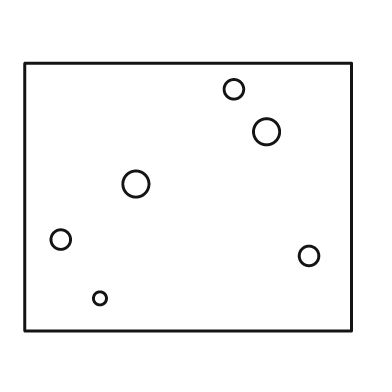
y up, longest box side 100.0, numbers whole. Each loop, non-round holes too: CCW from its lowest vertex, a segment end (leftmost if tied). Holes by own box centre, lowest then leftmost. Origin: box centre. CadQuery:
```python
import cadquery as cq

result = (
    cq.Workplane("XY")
    .moveTo(-50.0, -41.0)
    .lineTo(50.0, -41.0)
    .lineTo(50.0, 41.0)
    .lineTo(-50.0, 41.0)
    .close()
    .moveTo(-27.0, -31.0)
    .circle(2.0)
    .moveTo(37.0, -18.0)
    .circle(3.0)
    .moveTo(-39.0, -13.0)
    .circle(3.0)
    .moveTo(-16.0, 4.0)
    .circle(4.0)
    .moveTo(24.0, 20.0)
    .circle(4.0)
    .moveTo(14.0, 33.0)
    .circle(3.0)
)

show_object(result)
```